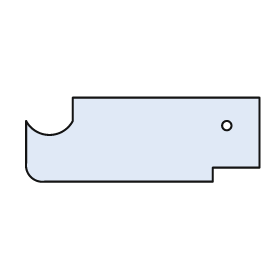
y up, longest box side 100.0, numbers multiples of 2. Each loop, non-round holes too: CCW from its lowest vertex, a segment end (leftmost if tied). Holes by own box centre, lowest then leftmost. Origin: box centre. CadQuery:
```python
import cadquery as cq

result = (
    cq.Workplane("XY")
    .moveTo(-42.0, -18.0)
    .lineTo(30.0, -18.0)
    .lineTo(30.0, -12.0)
    .lineTo(50.0, -12.0)
    .lineTo(50.0, 18.0)
    .lineTo(-30.0, 18.0)
    .lineTo(-30.0, 8.0)
    .threePointArc((-40.0, 2.0), (-50.0, 8.0))
    .lineTo(-50.0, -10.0)
    .threePointArc((-48.0, -16.0), (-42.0, -18.0))
    .close()
    .moveTo(36.0, 6.0)
    .circle(2.0)
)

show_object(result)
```